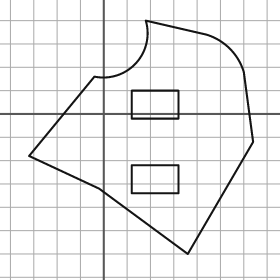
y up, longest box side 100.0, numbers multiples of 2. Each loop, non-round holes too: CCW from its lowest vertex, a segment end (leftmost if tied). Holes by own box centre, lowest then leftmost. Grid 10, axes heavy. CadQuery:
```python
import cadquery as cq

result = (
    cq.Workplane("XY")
    .moveTo(36.0, -60.0)
    .lineTo(64.0, -12.0)
    .lineTo(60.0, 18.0)
    .threePointArc((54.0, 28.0), (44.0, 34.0))
    .lineTo(18.0, 40.0)
    .threePointArc((14.0, 22.0), (-4.0, 16.0))
    .lineTo(-32.0, -18.0)
    .lineTo(-2.0, -32.0)
    .close()
    .moveTo(12.0, -34.0)
    .lineTo(32.0, -34.0)
    .lineTo(32.0, -22.0)
    .lineTo(12.0, -22.0)
    .close()
    .moveTo(12.0, -2.0)
    .lineTo(32.0, -2.0)
    .lineTo(32.0, 10.0)
    .lineTo(12.0, 10.0)
    .close()
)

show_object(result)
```